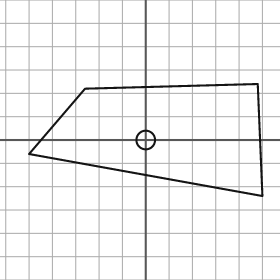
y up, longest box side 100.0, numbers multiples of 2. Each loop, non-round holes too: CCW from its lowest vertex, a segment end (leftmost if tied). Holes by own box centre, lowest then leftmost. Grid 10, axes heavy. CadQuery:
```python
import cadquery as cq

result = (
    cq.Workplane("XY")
    .moveTo(50.0, -24.0)
    .lineTo(48.0, 24.0)
    .lineTo(-26.0, 22.0)
    .lineTo(-50.0, -6.0)
    .close()
    .moveTo(0.0, 0.0)
    .circle(4.0)
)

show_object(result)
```